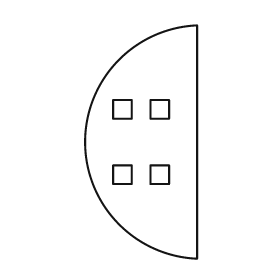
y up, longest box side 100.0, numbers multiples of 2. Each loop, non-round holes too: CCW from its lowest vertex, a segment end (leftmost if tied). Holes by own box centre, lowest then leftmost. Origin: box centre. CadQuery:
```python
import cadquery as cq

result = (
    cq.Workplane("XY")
    .moveTo(24.0, -50.0)
    .lineTo(24.0, 50.0)
    .threePointArc((-24.0, 0.0), (24.0, -50.0))
    .close()
    .moveTo(-12.0, -18.0)
    .lineTo(-4.0, -18.0)
    .lineTo(-4.0, -10.0)
    .lineTo(-12.0, -10.0)
    .close()
    .moveTo(4.0, -18.0)
    .lineTo(12.0, -18.0)
    .lineTo(12.0, -10.0)
    .lineTo(4.0, -10.0)
    .close()
    .moveTo(-12.0, 10.0)
    .lineTo(-4.0, 10.0)
    .lineTo(-4.0, 18.0)
    .lineTo(-12.0, 18.0)
    .close()
    .moveTo(4.0, 10.0)
    .lineTo(12.0, 10.0)
    .lineTo(12.0, 18.0)
    .lineTo(4.0, 18.0)
    .close()
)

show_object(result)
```